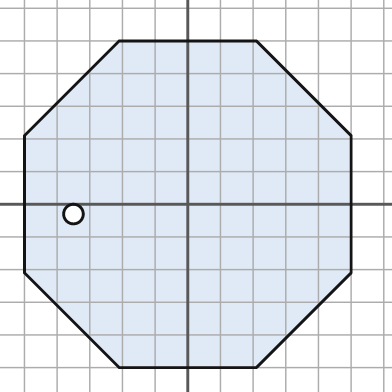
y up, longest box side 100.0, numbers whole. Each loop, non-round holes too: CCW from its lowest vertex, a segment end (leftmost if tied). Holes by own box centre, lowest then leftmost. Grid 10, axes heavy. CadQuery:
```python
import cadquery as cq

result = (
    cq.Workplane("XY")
    .moveTo(-21.0, -50.0)
    .lineTo(21.0, -50.0)
    .lineTo(50.0, -21.0)
    .lineTo(50.0, 21.0)
    .lineTo(21.0, 50.0)
    .lineTo(-21.0, 50.0)
    .lineTo(-50.0, 21.0)
    .lineTo(-50.0, -21.0)
    .close()
    .moveTo(-35.0, -3.0)
    .circle(3.0)
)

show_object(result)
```